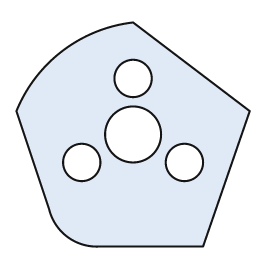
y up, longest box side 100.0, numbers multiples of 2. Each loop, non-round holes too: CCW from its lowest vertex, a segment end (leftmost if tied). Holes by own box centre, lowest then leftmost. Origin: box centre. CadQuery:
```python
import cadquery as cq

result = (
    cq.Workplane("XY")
    .moveTo(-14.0, -48.0)
    .lineTo(30.0, -48.0)
    .lineTo(50.0, 10.0)
    .lineTo(0.0, 48.0)
    .threePointArc((-30.0, 36.0), (-50.0, 10.0))
    .lineTo(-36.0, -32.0)
    .threePointArc((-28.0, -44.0), (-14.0, -48.0))
    .close()
    .moveTo(-22.0, -12.0)
    .circle(8.0)
    .moveTo(22.0, -12.0)
    .circle(8.0)
    .moveTo(0.0, 0.0)
    .circle(12.0)
    .moveTo(0.0, 24.0)
    .circle(8.0)
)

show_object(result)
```